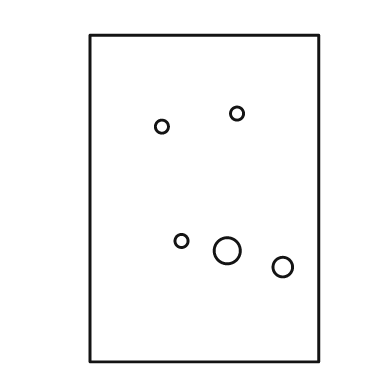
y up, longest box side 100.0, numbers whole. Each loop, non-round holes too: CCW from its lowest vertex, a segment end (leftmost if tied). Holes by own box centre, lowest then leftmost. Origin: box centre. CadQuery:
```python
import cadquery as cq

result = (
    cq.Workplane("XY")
    .moveTo(-35.0, -50.0)
    .lineTo(35.0, -50.0)
    .lineTo(35.0, 50.0)
    .lineTo(-35.0, 50.0)
    .close()
    .moveTo(24.0, -21.0)
    .circle(3.0)
    .moveTo(7.0, -16.0)
    .circle(4.0)
    .moveTo(-7.0, -13.0)
    .circle(2.0)
    .moveTo(-13.0, 22.0)
    .circle(2.0)
    .moveTo(10.0, 26.0)
    .circle(2.0)
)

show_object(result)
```